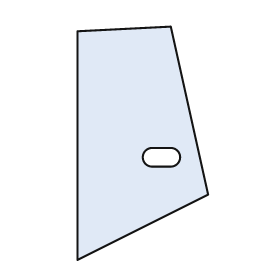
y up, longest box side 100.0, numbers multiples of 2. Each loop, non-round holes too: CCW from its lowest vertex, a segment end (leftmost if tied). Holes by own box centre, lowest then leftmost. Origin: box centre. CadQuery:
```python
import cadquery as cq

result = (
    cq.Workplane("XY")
    .moveTo(-28.0, -50.0)
    .lineTo(28.0, -22.0)
    .lineTo(12.0, 50.0)
    .lineTo(-28.0, 48.0)
    .close()
    .moveTo(4.0, -10.0)
    .lineTo(12.0, -10.0)
    .threePointArc((16.0, -6.0), (12.0, -2.0))
    .lineTo(4.0, -2.0)
    .threePointArc((0.0, -6.0), (4.0, -10.0))
    .close()
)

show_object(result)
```